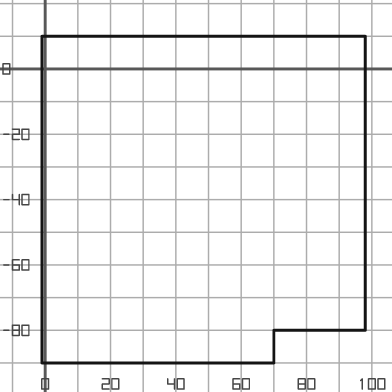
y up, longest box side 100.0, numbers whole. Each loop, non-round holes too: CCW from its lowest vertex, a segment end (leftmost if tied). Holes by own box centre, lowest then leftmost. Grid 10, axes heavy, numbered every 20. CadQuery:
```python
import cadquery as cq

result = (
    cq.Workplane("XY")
    .moveTo(-1.0, -90.0)
    .lineTo(70.0, -90.0)
    .lineTo(70.0, -80.0)
    .lineTo(98.0, -80.0)
    .lineTo(98.0, 10.0)
    .lineTo(-1.0, 10.0)
    .close()
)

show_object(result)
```